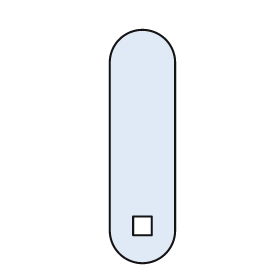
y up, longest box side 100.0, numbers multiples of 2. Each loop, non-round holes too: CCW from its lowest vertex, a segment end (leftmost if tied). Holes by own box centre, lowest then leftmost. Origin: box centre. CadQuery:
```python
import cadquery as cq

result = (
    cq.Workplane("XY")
    .moveTo(-14.0, -36.0)
    .threePointArc((0.0, -50.0), (14.0, -36.0))
    .lineTo(14.0, 36.0)
    .threePointArc((0.0, 50.0), (-14.0, 36.0))
    .close()
    .moveTo(-4.0, -38.0)
    .lineTo(4.0, -38.0)
    .lineTo(4.0, -30.0)
    .lineTo(-4.0, -30.0)
    .close()
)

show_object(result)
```